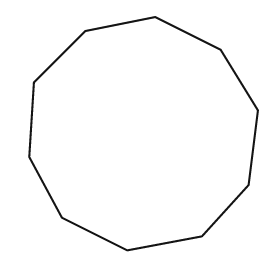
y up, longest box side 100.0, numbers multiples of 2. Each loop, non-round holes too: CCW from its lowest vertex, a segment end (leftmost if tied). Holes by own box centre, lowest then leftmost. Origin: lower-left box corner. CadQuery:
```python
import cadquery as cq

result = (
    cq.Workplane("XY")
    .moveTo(42.0, 0.0)
    .lineTo(74.0, 6.0)
    .lineTo(94.0, 28.0)
    .lineTo(98.0, 60.0)
    .lineTo(82.0, 86.0)
    .lineTo(54.0, 100.0)
    .lineTo(24.0, 94.0)
    .lineTo(2.0, 72.0)
    .lineTo(0.0, 40.0)
    .lineTo(14.0, 14.0)
    .close()
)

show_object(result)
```